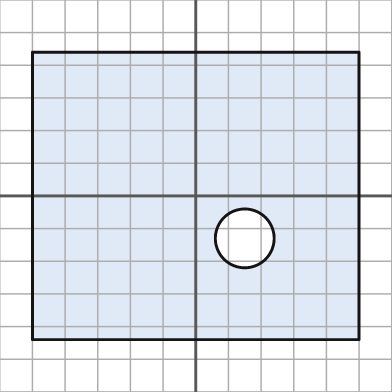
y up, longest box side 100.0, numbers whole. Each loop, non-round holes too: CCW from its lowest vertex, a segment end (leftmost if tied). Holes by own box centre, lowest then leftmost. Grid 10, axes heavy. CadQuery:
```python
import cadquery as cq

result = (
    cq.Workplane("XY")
    .moveTo(-50.0, -44.0)
    .lineTo(50.0, -44.0)
    .lineTo(50.0, 44.0)
    .lineTo(-50.0, 44.0)
    .close()
    .moveTo(15.0, -13.0)
    .circle(9.0)
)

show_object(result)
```